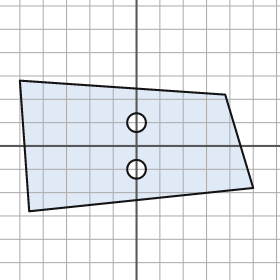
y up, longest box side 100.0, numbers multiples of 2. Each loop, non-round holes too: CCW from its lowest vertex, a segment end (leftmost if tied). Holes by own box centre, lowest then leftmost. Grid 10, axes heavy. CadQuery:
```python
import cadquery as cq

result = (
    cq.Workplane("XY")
    .moveTo(-46.0, -28.0)
    .lineTo(50.0, -18.0)
    .lineTo(38.0, 22.0)
    .lineTo(-50.0, 28.0)
    .close()
    .moveTo(0.0, -10.0)
    .circle(4.0)
    .moveTo(0.0, 10.0)
    .circle(4.0)
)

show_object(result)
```